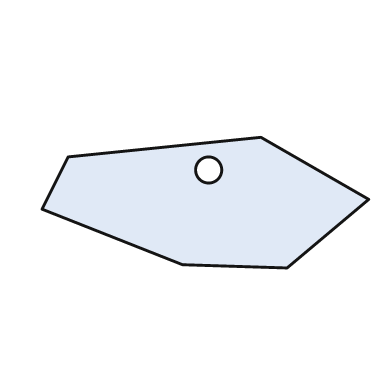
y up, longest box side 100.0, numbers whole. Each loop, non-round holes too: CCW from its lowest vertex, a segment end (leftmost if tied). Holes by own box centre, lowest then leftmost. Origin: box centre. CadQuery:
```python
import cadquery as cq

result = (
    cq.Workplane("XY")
    .moveTo(25.0, -20.0)
    .lineTo(50.0, 1.0)
    .lineTo(17.0, 20.0)
    .lineTo(-42.0, 14.0)
    .lineTo(-50.0, -2.0)
    .lineTo(-7.0, -19.0)
    .close()
    .moveTo(1.0, 10.0)
    .circle(4.0)
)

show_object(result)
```